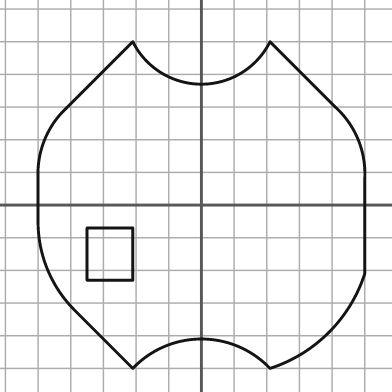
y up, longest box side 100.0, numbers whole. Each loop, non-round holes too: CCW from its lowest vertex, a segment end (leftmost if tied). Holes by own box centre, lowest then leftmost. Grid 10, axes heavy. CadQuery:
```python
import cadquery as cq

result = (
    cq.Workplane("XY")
    .moveTo(-21.0, -50.0)
    .threePointArc((0.0, -41.0), (21.0, -50.0))
    .threePointArc((39.0, -39.0), (50.0, -21.0))
    .lineTo(50.0, 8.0)
    .threePointArc((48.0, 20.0), (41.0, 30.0))
    .lineTo(21.0, 50.0)
    .threePointArc((0.0, 37.0), (-21.0, 50.0))
    .lineTo(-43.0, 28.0)
    .threePointArc((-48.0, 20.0), (-50.0, 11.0))
    .lineTo(-50.0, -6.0)
    .threePointArc((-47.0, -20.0), (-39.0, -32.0))
    .close()
    .moveTo(-35.0, -23.0)
    .lineTo(-21.0, -23.0)
    .lineTo(-21.0, -7.0)
    .lineTo(-35.0, -7.0)
    .close()
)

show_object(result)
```